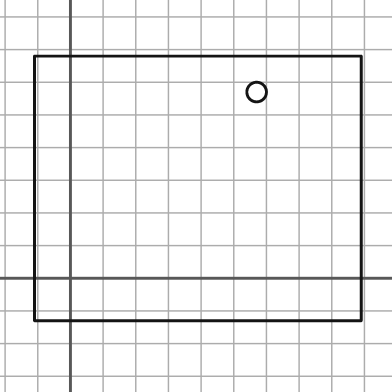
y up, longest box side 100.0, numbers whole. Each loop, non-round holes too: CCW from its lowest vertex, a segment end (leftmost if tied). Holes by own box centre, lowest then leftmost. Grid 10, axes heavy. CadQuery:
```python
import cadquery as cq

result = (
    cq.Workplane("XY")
    .moveTo(-11.0, -13.0)
    .lineTo(89.0, -13.0)
    .lineTo(89.0, 68.0)
    .lineTo(-11.0, 68.0)
    .close()
    .moveTo(57.0, 57.0)
    .circle(3.0)
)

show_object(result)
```